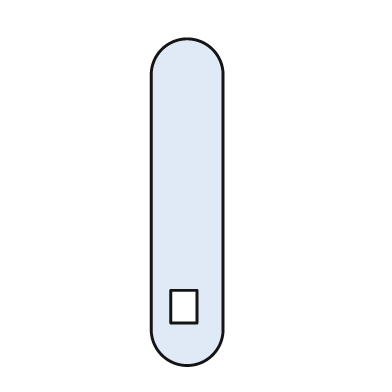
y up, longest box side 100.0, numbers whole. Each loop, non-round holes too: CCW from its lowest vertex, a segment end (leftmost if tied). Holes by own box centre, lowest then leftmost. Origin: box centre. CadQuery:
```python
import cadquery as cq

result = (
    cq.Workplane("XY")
    .moveTo(-11.0, -39.0)
    .threePointArc((0.0, -50.0), (11.0, -39.0))
    .lineTo(11.0, 39.0)
    .threePointArc((0.0, 50.0), (-11.0, 39.0))
    .close()
    .moveTo(-5.0, -37.0)
    .lineTo(3.0, -37.0)
    .lineTo(3.0, -27.0)
    .lineTo(-5.0, -27.0)
    .close()
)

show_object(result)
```